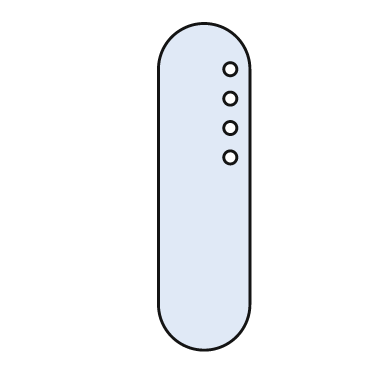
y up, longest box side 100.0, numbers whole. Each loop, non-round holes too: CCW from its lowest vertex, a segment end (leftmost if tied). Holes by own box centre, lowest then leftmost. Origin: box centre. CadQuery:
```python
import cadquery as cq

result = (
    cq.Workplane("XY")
    .moveTo(-14.0, -36.0)
    .threePointArc((0.0, -50.0), (14.0, -36.0))
    .lineTo(14.0, 36.0)
    .threePointArc((0.0, 50.0), (-14.0, 36.0))
    .close()
    .moveTo(8.0, 9.0)
    .circle(2.0)
    .moveTo(8.0, 18.0)
    .circle(2.0)
    .moveTo(8.0, 27.0)
    .circle(2.0)
    .moveTo(8.0, 36.0)
    .circle(2.0)
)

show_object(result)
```